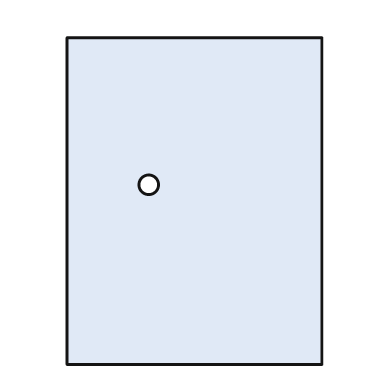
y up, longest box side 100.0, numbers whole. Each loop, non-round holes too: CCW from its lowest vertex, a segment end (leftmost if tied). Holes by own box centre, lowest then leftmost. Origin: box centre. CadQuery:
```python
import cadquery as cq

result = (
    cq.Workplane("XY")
    .moveTo(-39.0, -50.0)
    .lineTo(39.0, -50.0)
    .lineTo(39.0, 50.0)
    .lineTo(-39.0, 50.0)
    .close()
    .moveTo(-14.0, 5.0)
    .circle(3.0)
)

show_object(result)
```